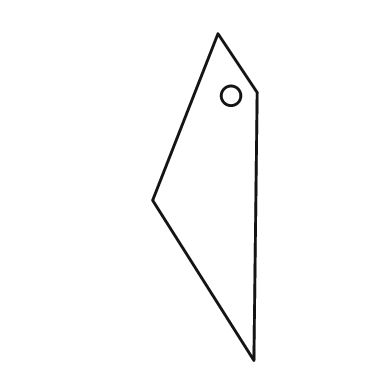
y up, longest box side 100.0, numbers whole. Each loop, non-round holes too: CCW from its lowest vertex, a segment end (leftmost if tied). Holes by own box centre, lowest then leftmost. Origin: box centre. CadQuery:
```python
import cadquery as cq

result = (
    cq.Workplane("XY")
    .moveTo(15.0, -50.0)
    .lineTo(16.0, 32.0)
    .lineTo(4.0, 50.0)
    .lineTo(-16.0, -1.0)
    .close()
    .moveTo(8.0, 31.0)
    .circle(3.0)
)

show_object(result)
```